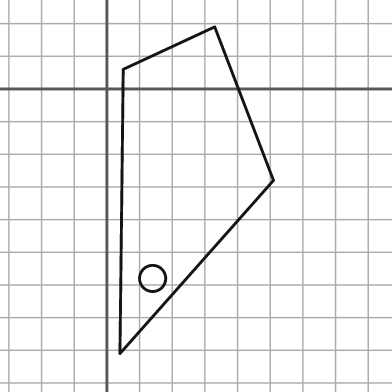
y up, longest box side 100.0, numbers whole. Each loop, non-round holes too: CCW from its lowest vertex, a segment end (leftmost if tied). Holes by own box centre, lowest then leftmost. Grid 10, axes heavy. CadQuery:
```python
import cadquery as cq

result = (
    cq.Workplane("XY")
    .moveTo(4.0, -81.0)
    .lineTo(51.0, -28.0)
    .lineTo(33.0, 19.0)
    .lineTo(5.0, 6.0)
    .close()
    .moveTo(14.0, -58.0)
    .circle(4.0)
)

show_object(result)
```